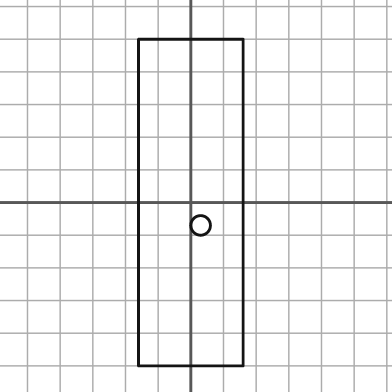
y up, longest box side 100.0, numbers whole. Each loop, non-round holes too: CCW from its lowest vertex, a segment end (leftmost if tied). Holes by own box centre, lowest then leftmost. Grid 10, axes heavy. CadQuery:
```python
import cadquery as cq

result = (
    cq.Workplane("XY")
    .moveTo(-16.0, -50.0)
    .lineTo(16.0, -50.0)
    .lineTo(16.0, 50.0)
    .lineTo(-16.0, 50.0)
    .close()
    .moveTo(3.0, -7.0)
    .circle(3.0)
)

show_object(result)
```